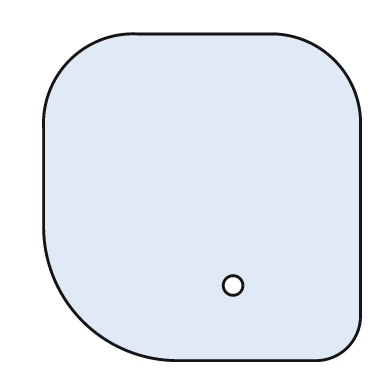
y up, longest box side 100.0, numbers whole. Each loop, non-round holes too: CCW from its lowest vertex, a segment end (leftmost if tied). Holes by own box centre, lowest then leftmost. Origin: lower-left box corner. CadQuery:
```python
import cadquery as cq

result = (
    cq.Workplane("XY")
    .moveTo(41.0, 0.0)
    .lineTo(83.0, 0.0)
    .threePointArc((93.0, 4.0), (97.0, 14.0))
    .lineTo(97.0, 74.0)
    .threePointArc((89.0, 92.0), (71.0, 100.0))
    .lineTo(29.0, 100.0)
    .threePointArc((8.0, 92.0), (0.0, 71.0))
    .lineTo(0.0, 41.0)
    .threePointArc((12.0, 12.0), (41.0, 0.0))
    .close()
    .moveTo(58.0, 23.0)
    .circle(3.0)
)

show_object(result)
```